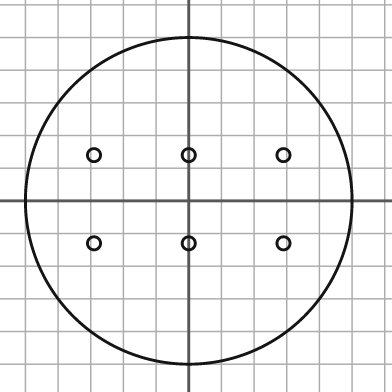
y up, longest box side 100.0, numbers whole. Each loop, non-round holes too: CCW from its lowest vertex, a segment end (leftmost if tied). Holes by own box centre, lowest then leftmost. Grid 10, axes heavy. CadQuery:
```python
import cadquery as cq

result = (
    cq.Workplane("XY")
    .moveTo(0.0, 0.0)
    .circle(50.0)
    .moveTo(-29.0, -13.0)
    .circle(2.0)
    .moveTo(0.0, -13.0)
    .circle(2.0)
    .moveTo(29.0, -13.0)
    .circle(2.0)
    .moveTo(-29.0, 14.0)
    .circle(2.0)
    .moveTo(0.0, 14.0)
    .circle(2.0)
    .moveTo(29.0, 14.0)
    .circle(2.0)
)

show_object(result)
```